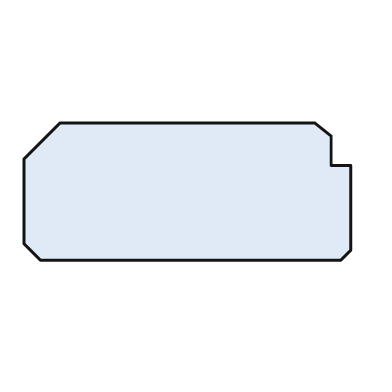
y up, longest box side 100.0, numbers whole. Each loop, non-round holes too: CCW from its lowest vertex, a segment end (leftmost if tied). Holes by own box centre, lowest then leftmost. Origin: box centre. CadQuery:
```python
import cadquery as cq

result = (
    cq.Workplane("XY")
    .moveTo(-45.0, -21.0)
    .lineTo(47.0, -21.0)
    .lineTo(50.0, -18.0)
    .lineTo(50.0, 8.0)
    .lineTo(44.0, 8.0)
    .lineTo(44.0, 17.0)
    .lineTo(39.0, 21.0)
    .lineTo(-39.0, 21.0)
    .lineTo(-50.0, 10.0)
    .lineTo(-50.0, -16.0)
    .close()
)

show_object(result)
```